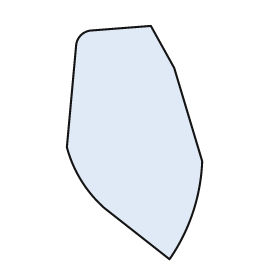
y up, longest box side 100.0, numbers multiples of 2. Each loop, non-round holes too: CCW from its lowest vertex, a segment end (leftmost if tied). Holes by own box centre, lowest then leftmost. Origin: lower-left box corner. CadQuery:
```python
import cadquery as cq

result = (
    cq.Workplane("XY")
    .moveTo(44.0, 0.0)
    .threePointArc((54.0, 20.0), (58.0, 42.0))
    .lineTo(46.0, 82.0)
    .lineTo(36.0, 100.0)
    .lineTo(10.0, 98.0)
    .threePointArc((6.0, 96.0), (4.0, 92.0))
    .lineTo(0.0, 48.0)
    .threePointArc((6.0, 34.0), (16.0, 22.0))
    .close()
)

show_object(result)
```